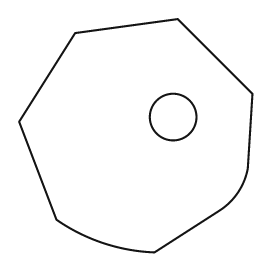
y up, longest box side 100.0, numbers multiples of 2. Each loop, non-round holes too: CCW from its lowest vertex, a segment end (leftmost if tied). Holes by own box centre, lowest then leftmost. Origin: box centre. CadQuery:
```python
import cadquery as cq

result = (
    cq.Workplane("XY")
    .moveTo(8.0, -50.0)
    .lineTo(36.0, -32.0)
    .threePointArc((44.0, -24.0), (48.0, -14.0))
    .lineTo(50.0, 18.0)
    .lineTo(18.0, 50.0)
    .lineTo(-26.0, 44.0)
    .lineTo(-50.0, 6.0)
    .lineTo(-34.0, -36.0)
    .threePointArc((-14.0, -46.0), (8.0, -50.0))
    .close()
    .moveTo(16.0, 8.0)
    .circle(10.0)
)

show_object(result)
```